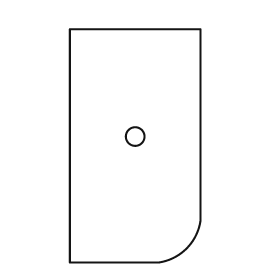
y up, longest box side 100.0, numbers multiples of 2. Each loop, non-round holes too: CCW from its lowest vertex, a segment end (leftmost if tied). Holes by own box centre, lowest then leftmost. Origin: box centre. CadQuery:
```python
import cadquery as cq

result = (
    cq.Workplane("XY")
    .moveTo(-28.0, -50.0)
    .lineTo(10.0, -50.0)
    .threePointArc((22.0, -44.0), (28.0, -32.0))
    .lineTo(28.0, 50.0)
    .lineTo(-28.0, 50.0)
    .close()
    .moveTo(0.0, 4.0)
    .circle(4.0)
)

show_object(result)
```